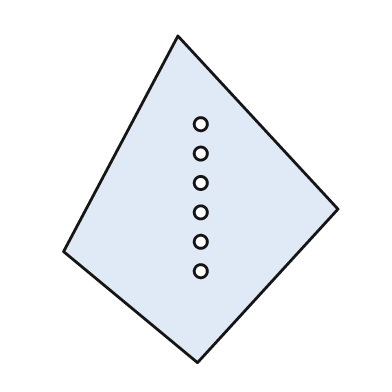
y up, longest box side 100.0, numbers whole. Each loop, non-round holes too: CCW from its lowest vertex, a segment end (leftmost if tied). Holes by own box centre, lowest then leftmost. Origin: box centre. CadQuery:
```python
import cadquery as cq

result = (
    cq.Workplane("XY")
    .moveTo(-1.0, -50.0)
    .lineTo(42.0, -3.0)
    .lineTo(-7.0, 50.0)
    .lineTo(-42.0, -16.0)
    .close()
    .moveTo(0.0, -22.0)
    .circle(2.0)
    .moveTo(0.0, -13.0)
    .circle(2.0)
    .moveTo(0.0, -4.0)
    .circle(2.0)
    .moveTo(0.0, 5.0)
    .circle(2.0)
    .moveTo(0.0, 14.0)
    .circle(2.0)
    .moveTo(0.0, 23.0)
    .circle(2.0)
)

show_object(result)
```